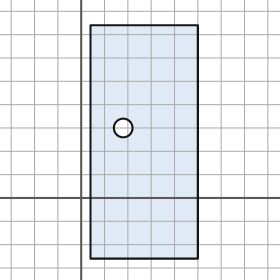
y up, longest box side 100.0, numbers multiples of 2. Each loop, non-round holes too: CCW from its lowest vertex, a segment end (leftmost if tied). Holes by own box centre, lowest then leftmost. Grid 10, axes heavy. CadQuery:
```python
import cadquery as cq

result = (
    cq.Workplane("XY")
    .moveTo(4.0, -26.0)
    .lineTo(50.0, -26.0)
    .lineTo(50.0, 74.0)
    .lineTo(4.0, 74.0)
    .close()
    .moveTo(18.0, 30.0)
    .circle(4.0)
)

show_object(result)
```